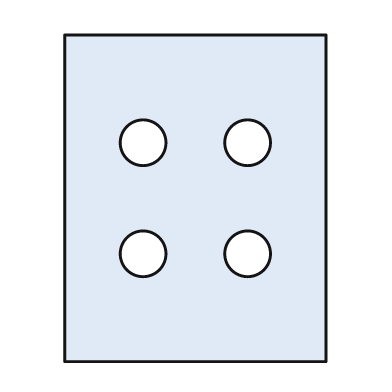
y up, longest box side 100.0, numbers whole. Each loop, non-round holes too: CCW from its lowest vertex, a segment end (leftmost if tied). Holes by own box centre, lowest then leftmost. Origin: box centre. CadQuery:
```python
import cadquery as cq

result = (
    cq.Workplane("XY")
    .moveTo(-40.0, -50.0)
    .lineTo(40.0, -50.0)
    .lineTo(40.0, 50.0)
    .lineTo(-40.0, 50.0)
    .close()
    .moveTo(-16.0, -17.0)
    .circle(7.0)
    .moveTo(16.0, -17.0)
    .circle(7.0)
    .moveTo(-16.0, 17.0)
    .circle(7.0)
    .moveTo(16.0, 17.0)
    .circle(7.0)
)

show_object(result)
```